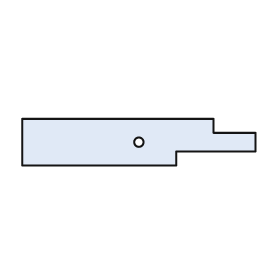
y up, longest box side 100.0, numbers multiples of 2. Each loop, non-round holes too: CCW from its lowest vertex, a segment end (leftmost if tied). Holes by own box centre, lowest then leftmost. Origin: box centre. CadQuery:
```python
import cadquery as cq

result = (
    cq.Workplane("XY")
    .moveTo(-50.0, -10.0)
    .lineTo(16.0, -10.0)
    .lineTo(16.0, -4.0)
    .lineTo(50.0, -4.0)
    .lineTo(50.0, 4.0)
    .lineTo(32.0, 4.0)
    .lineTo(32.0, 10.0)
    .lineTo(-50.0, 10.0)
    .close()
    .moveTo(0.0, 0.0)
    .circle(2.0)
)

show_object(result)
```